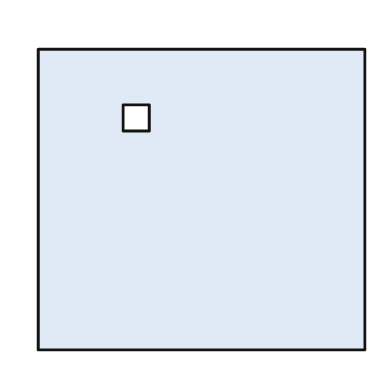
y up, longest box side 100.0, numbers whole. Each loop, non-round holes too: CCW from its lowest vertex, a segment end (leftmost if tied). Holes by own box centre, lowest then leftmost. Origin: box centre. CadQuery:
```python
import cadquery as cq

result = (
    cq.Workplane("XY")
    .moveTo(-50.0, -46.0)
    .lineTo(50.0, -46.0)
    .lineTo(50.0, 46.0)
    .lineTo(-50.0, 46.0)
    .close()
    .moveTo(-24.0, 21.0)
    .lineTo(-16.0, 21.0)
    .lineTo(-16.0, 29.0)
    .lineTo(-24.0, 29.0)
    .close()
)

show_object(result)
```